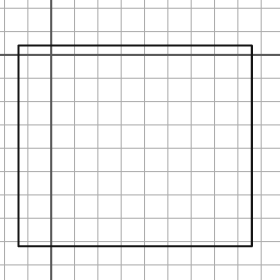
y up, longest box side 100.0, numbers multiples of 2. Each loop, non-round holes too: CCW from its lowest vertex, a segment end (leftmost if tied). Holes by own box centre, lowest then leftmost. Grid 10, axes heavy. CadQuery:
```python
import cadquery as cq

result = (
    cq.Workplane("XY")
    .moveTo(-14.0, -82.0)
    .lineTo(86.0, -82.0)
    .lineTo(86.0, 4.0)
    .lineTo(-14.0, 4.0)
    .close()
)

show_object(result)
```